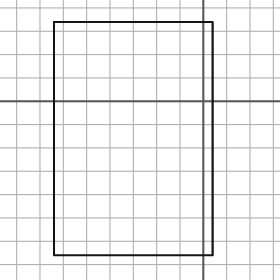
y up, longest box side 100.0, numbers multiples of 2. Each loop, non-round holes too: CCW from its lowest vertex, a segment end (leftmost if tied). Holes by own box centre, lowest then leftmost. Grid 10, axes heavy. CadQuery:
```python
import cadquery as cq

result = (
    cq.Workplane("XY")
    .moveTo(-64.0, -66.0)
    .lineTo(4.0, -66.0)
    .lineTo(4.0, 34.0)
    .lineTo(-64.0, 34.0)
    .close()
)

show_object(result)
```